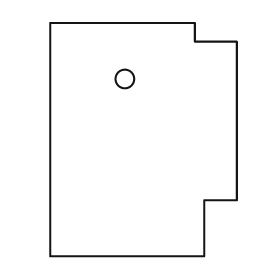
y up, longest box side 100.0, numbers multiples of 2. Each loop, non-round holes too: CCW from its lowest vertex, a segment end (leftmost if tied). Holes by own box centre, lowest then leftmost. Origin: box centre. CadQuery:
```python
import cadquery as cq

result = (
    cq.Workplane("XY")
    .moveTo(-40.0, -50.0)
    .lineTo(26.0, -50.0)
    .lineTo(26.0, -26.0)
    .lineTo(40.0, -26.0)
    .lineTo(40.0, 42.0)
    .lineTo(22.0, 42.0)
    .lineTo(22.0, 50.0)
    .lineTo(-40.0, 50.0)
    .close()
    .moveTo(-8.0, 26.0)
    .circle(4.0)
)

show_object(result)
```